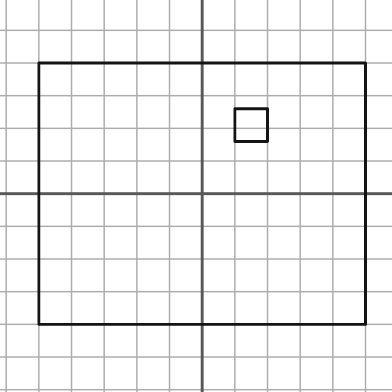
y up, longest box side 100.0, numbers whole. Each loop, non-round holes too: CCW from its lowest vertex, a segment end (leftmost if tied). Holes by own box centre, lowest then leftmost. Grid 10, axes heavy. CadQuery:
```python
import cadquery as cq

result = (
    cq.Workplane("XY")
    .moveTo(-50.0, -40.0)
    .lineTo(50.0, -40.0)
    .lineTo(50.0, 40.0)
    .lineTo(-50.0, 40.0)
    .close()
    .moveTo(10.0, 16.0)
    .lineTo(20.0, 16.0)
    .lineTo(20.0, 26.0)
    .lineTo(10.0, 26.0)
    .close()
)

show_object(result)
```